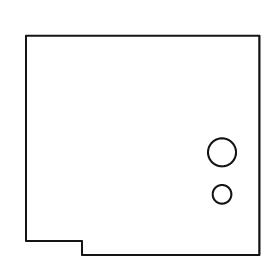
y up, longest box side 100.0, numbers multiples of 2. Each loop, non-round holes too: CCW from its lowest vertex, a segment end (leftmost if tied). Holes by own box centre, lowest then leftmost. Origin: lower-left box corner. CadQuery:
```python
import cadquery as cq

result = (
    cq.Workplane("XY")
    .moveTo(24.0, 0.0)
    .lineTo(100.0, 0.0)
    .lineTo(100.0, 94.0)
    .lineTo(0.0, 94.0)
    .lineTo(0.0, 6.0)
    .lineTo(24.0, 6.0)
    .close()
    .moveTo(84.0, 26.0)
    .circle(4.0)
    .moveTo(84.0, 44.0)
    .circle(6.0)
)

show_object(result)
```